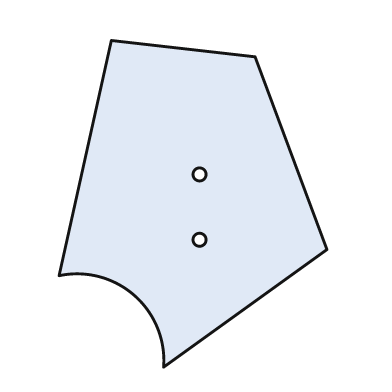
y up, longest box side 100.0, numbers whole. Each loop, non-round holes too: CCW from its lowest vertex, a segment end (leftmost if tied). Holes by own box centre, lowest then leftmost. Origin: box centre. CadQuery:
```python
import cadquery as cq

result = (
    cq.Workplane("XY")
    .moveTo(-9.0, -50.0)
    .lineTo(41.0, -14.0)
    .lineTo(19.0, 45.0)
    .lineTo(-25.0, 50.0)
    .lineTo(-41.0, -22.0)
    .threePointArc((-18.0, -28.0), (-9.0, -50.0))
    .close()
    .moveTo(2.0, -11.0)
    .circle(2.0)
    .moveTo(2.0, 9.0)
    .circle(2.0)
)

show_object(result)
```